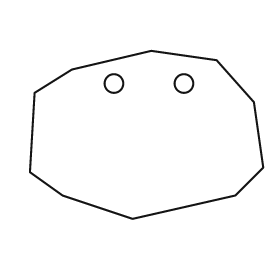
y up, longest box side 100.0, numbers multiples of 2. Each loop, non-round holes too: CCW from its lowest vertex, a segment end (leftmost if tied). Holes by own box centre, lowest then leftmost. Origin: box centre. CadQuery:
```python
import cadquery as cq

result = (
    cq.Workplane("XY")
    .moveTo(-6.0, -36.0)
    .lineTo(38.0, -26.0)
    .lineTo(50.0, -14.0)
    .lineTo(46.0, 14.0)
    .lineTo(30.0, 32.0)
    .lineTo(2.0, 36.0)
    .lineTo(-32.0, 28.0)
    .lineTo(-48.0, 18.0)
    .lineTo(-50.0, -16.0)
    .lineTo(-36.0, -26.0)
    .close()
    .moveTo(-14.0, 22.0)
    .circle(4.0)
    .moveTo(16.0, 22.0)
    .circle(4.0)
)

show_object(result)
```